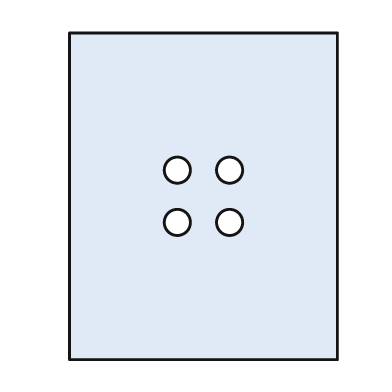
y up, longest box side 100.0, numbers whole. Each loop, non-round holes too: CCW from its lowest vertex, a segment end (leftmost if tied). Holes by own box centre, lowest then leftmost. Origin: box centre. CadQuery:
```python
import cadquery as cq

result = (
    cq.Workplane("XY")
    .moveTo(-41.0, -50.0)
    .lineTo(41.0, -50.0)
    .lineTo(41.0, 50.0)
    .lineTo(-41.0, 50.0)
    .close()
    .moveTo(-8.0, -8.0)
    .circle(4.0)
    .moveTo(8.0, -8.0)
    .circle(4.0)
    .moveTo(-8.0, 8.0)
    .circle(4.0)
    .moveTo(8.0, 8.0)
    .circle(4.0)
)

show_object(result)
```